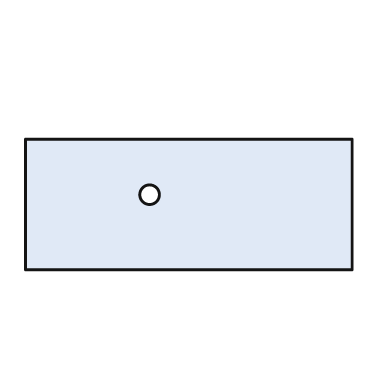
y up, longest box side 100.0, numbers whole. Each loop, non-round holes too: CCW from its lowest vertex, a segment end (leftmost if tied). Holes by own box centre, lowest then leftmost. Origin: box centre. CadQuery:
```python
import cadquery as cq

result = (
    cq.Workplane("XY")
    .moveTo(-50.0, -20.0)
    .lineTo(50.0, -20.0)
    .lineTo(50.0, 20.0)
    .lineTo(-50.0, 20.0)
    .close()
    .moveTo(-12.0, 3.0)
    .circle(3.0)
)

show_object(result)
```